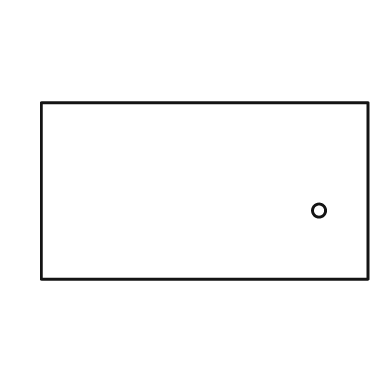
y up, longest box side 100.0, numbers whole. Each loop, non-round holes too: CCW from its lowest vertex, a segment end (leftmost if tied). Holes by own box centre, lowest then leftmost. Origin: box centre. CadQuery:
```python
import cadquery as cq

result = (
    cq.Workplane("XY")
    .moveTo(-50.0, -27.0)
    .lineTo(50.0, -27.0)
    .lineTo(50.0, 27.0)
    .lineTo(-50.0, 27.0)
    .close()
    .moveTo(35.0, -6.0)
    .circle(2.0)
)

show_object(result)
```